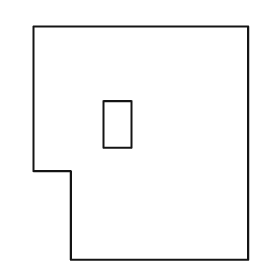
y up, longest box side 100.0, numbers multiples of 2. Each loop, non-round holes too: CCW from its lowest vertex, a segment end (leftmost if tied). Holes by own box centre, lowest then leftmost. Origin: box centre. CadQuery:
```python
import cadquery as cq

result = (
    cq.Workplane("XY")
    .moveTo(-30.0, -50.0)
    .lineTo(46.0, -50.0)
    .lineTo(46.0, 50.0)
    .lineTo(-46.0, 50.0)
    .lineTo(-46.0, -12.0)
    .lineTo(-30.0, -12.0)
    .close()
    .moveTo(-16.0, -2.0)
    .lineTo(-4.0, -2.0)
    .lineTo(-4.0, 18.0)
    .lineTo(-16.0, 18.0)
    .close()
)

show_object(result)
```